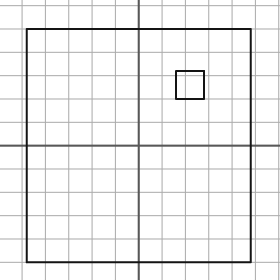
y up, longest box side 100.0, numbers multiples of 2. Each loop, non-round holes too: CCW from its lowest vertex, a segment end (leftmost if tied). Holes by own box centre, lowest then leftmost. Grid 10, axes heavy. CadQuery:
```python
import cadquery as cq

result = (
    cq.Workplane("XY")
    .moveTo(-48.0, -50.0)
    .lineTo(48.0, -50.0)
    .lineTo(48.0, 50.0)
    .lineTo(-48.0, 50.0)
    .close()
    .moveTo(16.0, 20.0)
    .lineTo(28.0, 20.0)
    .lineTo(28.0, 32.0)
    .lineTo(16.0, 32.0)
    .close()
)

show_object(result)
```